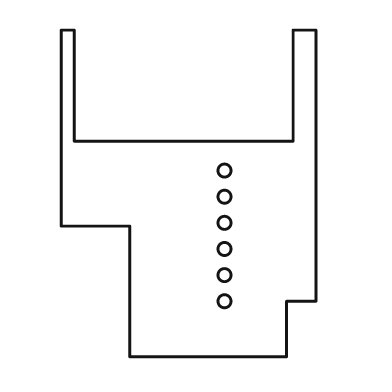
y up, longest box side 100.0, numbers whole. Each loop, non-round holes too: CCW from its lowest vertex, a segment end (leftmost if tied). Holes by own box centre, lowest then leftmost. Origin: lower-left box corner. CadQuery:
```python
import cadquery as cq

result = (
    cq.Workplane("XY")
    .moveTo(21.0, 0.0)
    .lineTo(69.0, 0.0)
    .lineTo(69.0, 17.0)
    .lineTo(78.0, 17.0)
    .lineTo(78.0, 100.0)
    .lineTo(71.0, 100.0)
    .lineTo(71.0, 66.0)
    .lineTo(4.0, 66.0)
    .lineTo(4.0, 100.0)
    .lineTo(0.0, 100.0)
    .lineTo(0.0, 40.0)
    .lineTo(21.0, 40.0)
    .close()
    .moveTo(50.0, 17.0)
    .circle(2.0)
    .moveTo(50.0, 25.0)
    .circle(2.0)
    .moveTo(50.0, 33.0)
    .circle(2.0)
    .moveTo(50.0, 41.0)
    .circle(2.0)
    .moveTo(50.0, 49.0)
    .circle(2.0)
    .moveTo(50.0, 57.0)
    .circle(2.0)
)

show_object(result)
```